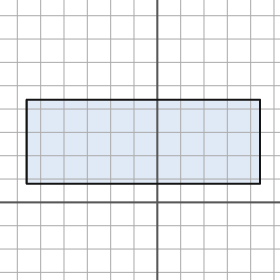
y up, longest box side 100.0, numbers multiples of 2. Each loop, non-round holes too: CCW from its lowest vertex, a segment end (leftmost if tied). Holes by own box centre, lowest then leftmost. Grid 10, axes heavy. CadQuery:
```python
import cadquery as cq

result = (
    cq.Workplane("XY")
    .moveTo(-56.0, 8.0)
    .lineTo(44.0, 8.0)
    .lineTo(44.0, 44.0)
    .lineTo(-56.0, 44.0)
    .close()
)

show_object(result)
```